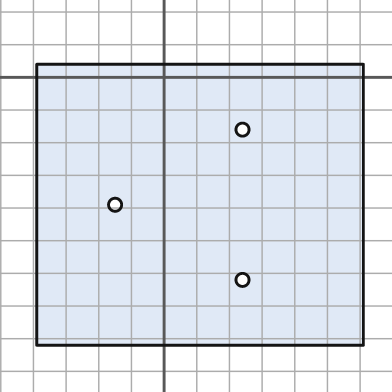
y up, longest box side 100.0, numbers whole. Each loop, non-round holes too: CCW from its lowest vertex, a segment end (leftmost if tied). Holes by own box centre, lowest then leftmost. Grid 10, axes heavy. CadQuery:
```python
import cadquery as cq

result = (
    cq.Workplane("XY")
    .moveTo(-39.0, -82.0)
    .lineTo(61.0, -82.0)
    .lineTo(61.0, 4.0)
    .lineTo(-39.0, 4.0)
    .close()
    .moveTo(24.0, -62.0)
    .circle(2.0)
    .moveTo(-15.0, -39.0)
    .circle(2.0)
    .moveTo(24.0, -16.0)
    .circle(2.0)
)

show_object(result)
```